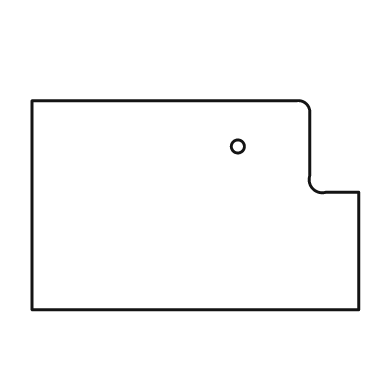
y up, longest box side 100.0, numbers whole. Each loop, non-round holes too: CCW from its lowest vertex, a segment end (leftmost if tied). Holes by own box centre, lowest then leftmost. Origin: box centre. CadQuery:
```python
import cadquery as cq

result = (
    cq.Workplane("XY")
    .moveTo(-50.0, -32.0)
    .lineTo(50.0, -32.0)
    .lineTo(50.0, 4.0)
    .lineTo(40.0, 4.0)
    .threePointArc((36.0, 5.0), (35.0, 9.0))
    .lineTo(35.0, 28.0)
    .threePointArc((34.0, 31.0), (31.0, 32.0))
    .lineTo(-50.0, 32.0)
    .close()
    .moveTo(13.0, 18.0)
    .circle(2.0)
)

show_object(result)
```